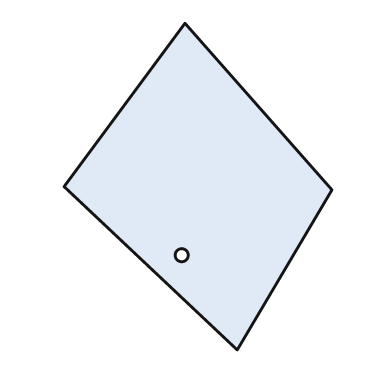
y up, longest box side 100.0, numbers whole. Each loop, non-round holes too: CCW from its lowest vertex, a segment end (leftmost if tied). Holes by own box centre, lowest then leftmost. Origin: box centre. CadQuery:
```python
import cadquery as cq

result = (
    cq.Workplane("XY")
    .moveTo(12.0, -50.0)
    .lineTo(41.0, -1.0)
    .lineTo(-4.0, 50.0)
    .lineTo(-41.0, 0.0)
    .close()
    .moveTo(-5.0, -21.0)
    .circle(2.0)
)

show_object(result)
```